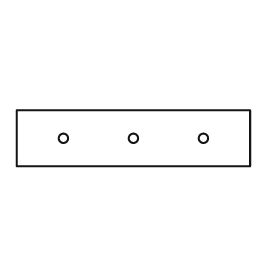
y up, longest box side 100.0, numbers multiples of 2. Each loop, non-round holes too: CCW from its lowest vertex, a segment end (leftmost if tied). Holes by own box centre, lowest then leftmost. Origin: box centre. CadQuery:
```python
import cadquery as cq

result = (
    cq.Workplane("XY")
    .moveTo(-50.0, -12.0)
    .lineTo(50.0, -12.0)
    .lineTo(50.0, 12.0)
    .lineTo(-50.0, 12.0)
    .close()
    .moveTo(-30.0, 0.0)
    .circle(2.0)
    .moveTo(0.0, 0.0)
    .circle(2.0)
    .moveTo(30.0, 0.0)
    .circle(2.0)
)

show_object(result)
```